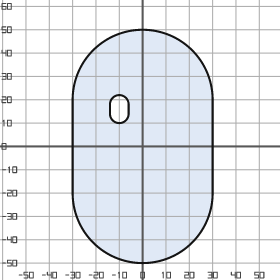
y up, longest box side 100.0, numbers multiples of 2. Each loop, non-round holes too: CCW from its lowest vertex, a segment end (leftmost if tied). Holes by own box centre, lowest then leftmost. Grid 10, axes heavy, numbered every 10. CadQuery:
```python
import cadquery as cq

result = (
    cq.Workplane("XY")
    .moveTo(-30.0, -20.0)
    .threePointArc((0.0, -50.0), (30.0, -20.0))
    .lineTo(30.0, 20.0)
    .threePointArc((0.0, 50.0), (-30.0, 20.0))
    .close()
    .moveTo(-14.0, 14.0)
    .threePointArc((-10.0, 10.0), (-6.0, 14.0))
    .lineTo(-6.0, 18.0)
    .threePointArc((-10.0, 22.0), (-14.0, 18.0))
    .close()
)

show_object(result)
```